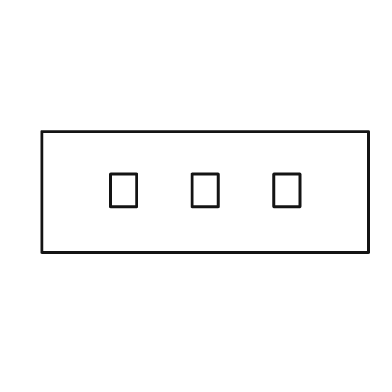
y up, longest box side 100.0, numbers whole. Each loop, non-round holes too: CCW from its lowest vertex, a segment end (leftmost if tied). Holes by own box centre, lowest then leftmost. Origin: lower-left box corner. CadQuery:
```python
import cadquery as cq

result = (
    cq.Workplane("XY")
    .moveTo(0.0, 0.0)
    .lineTo(100.0, 0.0)
    .lineTo(100.0, 37.0)
    .lineTo(0.0, 37.0)
    .close()
    .moveTo(21.0, 14.0)
    .lineTo(29.0, 14.0)
    .lineTo(29.0, 24.0)
    .lineTo(21.0, 24.0)
    .close()
    .moveTo(46.0, 14.0)
    .lineTo(54.0, 14.0)
    .lineTo(54.0, 24.0)
    .lineTo(46.0, 24.0)
    .close()
    .moveTo(71.0, 14.0)
    .lineTo(79.0, 14.0)
    .lineTo(79.0, 24.0)
    .lineTo(71.0, 24.0)
    .close()
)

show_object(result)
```